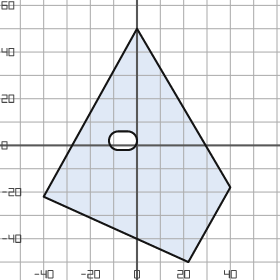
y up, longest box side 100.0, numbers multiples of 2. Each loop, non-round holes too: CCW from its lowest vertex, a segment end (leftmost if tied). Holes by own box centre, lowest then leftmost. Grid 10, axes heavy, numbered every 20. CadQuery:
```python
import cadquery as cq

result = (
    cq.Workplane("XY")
    .moveTo(22.0, -50.0)
    .lineTo(40.0, -18.0)
    .lineTo(0.0, 50.0)
    .lineTo(-40.0, -22.0)
    .close()
    .moveTo(-8.0, -2.0)
    .lineTo(-4.0, -2.0)
    .threePointArc((0.0, 2.0), (-4.0, 6.0))
    .lineTo(-8.0, 6.0)
    .threePointArc((-12.0, 2.0), (-8.0, -2.0))
    .close()
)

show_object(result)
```